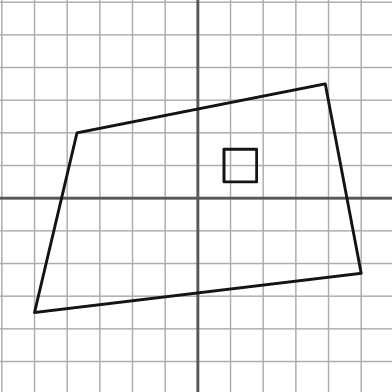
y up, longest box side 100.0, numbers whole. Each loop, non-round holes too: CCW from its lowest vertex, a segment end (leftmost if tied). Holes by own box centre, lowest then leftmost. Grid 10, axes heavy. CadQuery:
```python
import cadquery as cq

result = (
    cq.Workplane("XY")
    .moveTo(-50.0, -35.0)
    .lineTo(50.0, -23.0)
    .lineTo(39.0, 35.0)
    .lineTo(-37.0, 20.0)
    .close()
    .moveTo(8.0, 5.0)
    .lineTo(18.0, 5.0)
    .lineTo(18.0, 15.0)
    .lineTo(8.0, 15.0)
    .close()
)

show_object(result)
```